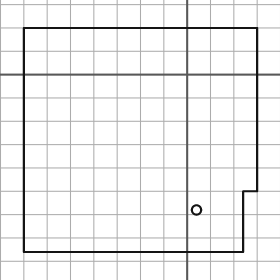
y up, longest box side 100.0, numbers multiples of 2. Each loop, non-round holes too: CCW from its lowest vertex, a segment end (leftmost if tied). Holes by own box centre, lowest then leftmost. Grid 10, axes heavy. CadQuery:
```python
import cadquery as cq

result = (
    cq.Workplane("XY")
    .moveTo(-70.0, -76.0)
    .lineTo(24.0, -76.0)
    .lineTo(24.0, -50.0)
    .lineTo(30.0, -50.0)
    .lineTo(30.0, 20.0)
    .lineTo(-70.0, 20.0)
    .close()
    .moveTo(4.0, -58.0)
    .circle(2.0)
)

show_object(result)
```